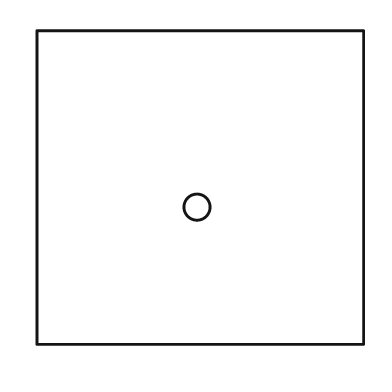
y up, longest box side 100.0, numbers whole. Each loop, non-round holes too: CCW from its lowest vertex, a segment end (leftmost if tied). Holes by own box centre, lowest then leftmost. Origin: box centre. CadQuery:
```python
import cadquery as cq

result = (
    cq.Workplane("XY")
    .moveTo(-50.0, -48.0)
    .lineTo(50.0, -48.0)
    .lineTo(50.0, 48.0)
    .lineTo(-50.0, 48.0)
    .close()
    .moveTo(-1.0, -6.0)
    .circle(4.0)
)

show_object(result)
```